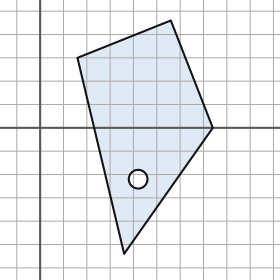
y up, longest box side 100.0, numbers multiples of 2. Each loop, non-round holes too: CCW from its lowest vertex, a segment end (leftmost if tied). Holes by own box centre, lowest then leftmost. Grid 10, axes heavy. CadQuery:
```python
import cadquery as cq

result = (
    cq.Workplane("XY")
    .moveTo(36.0, -54.0)
    .lineTo(74.0, 0.0)
    .lineTo(56.0, 46.0)
    .lineTo(16.0, 30.0)
    .close()
    .moveTo(42.0, -22.0)
    .circle(4.0)
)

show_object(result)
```